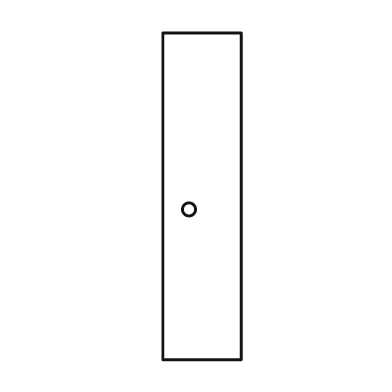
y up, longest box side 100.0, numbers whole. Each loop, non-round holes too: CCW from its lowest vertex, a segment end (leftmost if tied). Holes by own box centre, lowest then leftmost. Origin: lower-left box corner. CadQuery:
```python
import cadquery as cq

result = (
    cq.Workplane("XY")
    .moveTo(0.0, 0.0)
    .lineTo(24.0, 0.0)
    .lineTo(24.0, 100.0)
    .lineTo(0.0, 100.0)
    .close()
    .moveTo(8.0, 46.0)
    .circle(2.0)
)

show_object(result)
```